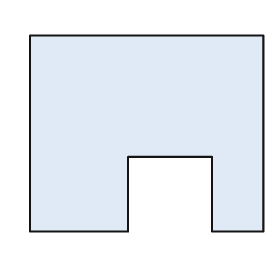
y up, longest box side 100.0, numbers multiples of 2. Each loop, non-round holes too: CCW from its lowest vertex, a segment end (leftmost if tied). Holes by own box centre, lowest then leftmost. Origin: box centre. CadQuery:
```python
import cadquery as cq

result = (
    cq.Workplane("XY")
    .moveTo(-50.0, -42.0)
    .lineTo(-8.0, -42.0)
    .lineTo(-8.0, -10.0)
    .lineTo(28.0, -10.0)
    .lineTo(28.0, -42.0)
    .lineTo(50.0, -42.0)
    .lineTo(50.0, 42.0)
    .lineTo(-50.0, 42.0)
    .close()
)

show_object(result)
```